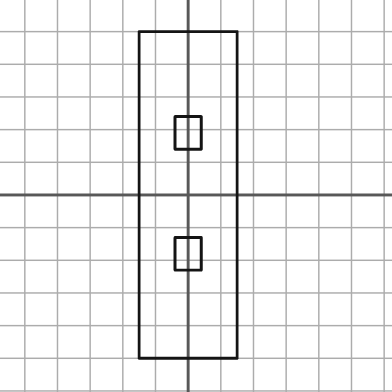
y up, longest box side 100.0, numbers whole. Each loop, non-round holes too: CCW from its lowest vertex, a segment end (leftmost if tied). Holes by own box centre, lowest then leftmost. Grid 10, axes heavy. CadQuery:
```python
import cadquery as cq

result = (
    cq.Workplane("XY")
    .moveTo(-15.0, -50.0)
    .lineTo(15.0, -50.0)
    .lineTo(15.0, 50.0)
    .lineTo(-15.0, 50.0)
    .close()
    .moveTo(-4.0, -23.0)
    .lineTo(4.0, -23.0)
    .lineTo(4.0, -13.0)
    .lineTo(-4.0, -13.0)
    .close()
    .moveTo(-4.0, 14.0)
    .lineTo(4.0, 14.0)
    .lineTo(4.0, 24.0)
    .lineTo(-4.0, 24.0)
    .close()
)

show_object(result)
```